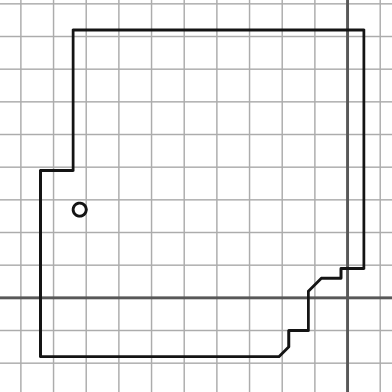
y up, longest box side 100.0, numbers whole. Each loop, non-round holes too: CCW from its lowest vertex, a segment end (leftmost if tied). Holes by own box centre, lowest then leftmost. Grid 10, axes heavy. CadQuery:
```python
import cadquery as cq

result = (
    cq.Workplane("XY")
    .moveTo(-94.0, -18.0)
    .lineTo(-21.0, -18.0)
    .lineTo(-18.0, -15.0)
    .lineTo(-18.0, -10.0)
    .lineTo(-12.0, -10.0)
    .lineTo(-12.0, 2.0)
    .lineTo(-8.0, 6.0)
    .lineTo(-2.0, 6.0)
    .lineTo(-2.0, 9.0)
    .lineTo(5.0, 9.0)
    .lineTo(5.0, 82.0)
    .lineTo(-84.0, 82.0)
    .lineTo(-84.0, 39.0)
    .lineTo(-94.0, 39.0)
    .close()
    .moveTo(-82.0, 27.0)
    .circle(2.0)
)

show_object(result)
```